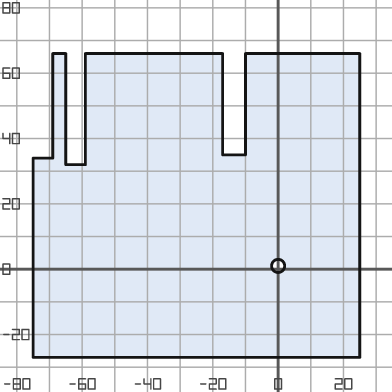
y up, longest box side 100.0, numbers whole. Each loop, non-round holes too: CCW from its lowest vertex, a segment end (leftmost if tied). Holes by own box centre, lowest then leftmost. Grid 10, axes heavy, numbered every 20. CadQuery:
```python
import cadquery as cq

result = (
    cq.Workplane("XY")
    .moveTo(-75.0, -27.0)
    .lineTo(25.0, -27.0)
    .lineTo(25.0, 66.0)
    .lineTo(-10.0, 66.0)
    .lineTo(-10.0, 35.0)
    .lineTo(-17.0, 35.0)
    .lineTo(-17.0, 66.0)
    .lineTo(-59.0, 66.0)
    .lineTo(-59.0, 32.0)
    .lineTo(-65.0, 32.0)
    .lineTo(-65.0, 66.0)
    .lineTo(-69.0, 66.0)
    .lineTo(-69.0, 34.0)
    .lineTo(-75.0, 34.0)
    .close()
    .moveTo(0.0, 1.0)
    .circle(2.0)
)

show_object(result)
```